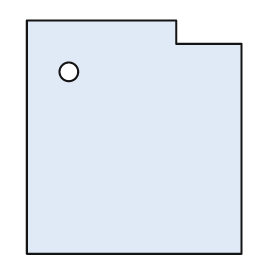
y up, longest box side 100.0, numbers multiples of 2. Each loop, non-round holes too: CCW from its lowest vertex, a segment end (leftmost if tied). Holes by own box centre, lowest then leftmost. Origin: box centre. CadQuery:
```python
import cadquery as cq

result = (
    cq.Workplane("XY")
    .moveTo(-46.0, -50.0)
    .lineTo(46.0, -50.0)
    .lineTo(46.0, 40.0)
    .lineTo(18.0, 40.0)
    .lineTo(18.0, 50.0)
    .lineTo(-46.0, 50.0)
    .close()
    .moveTo(-28.0, 28.0)
    .circle(4.0)
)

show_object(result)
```